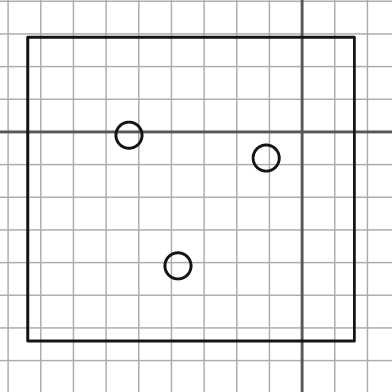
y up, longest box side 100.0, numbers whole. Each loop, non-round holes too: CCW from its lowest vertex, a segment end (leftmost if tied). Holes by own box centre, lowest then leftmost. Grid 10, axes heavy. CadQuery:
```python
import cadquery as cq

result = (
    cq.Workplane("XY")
    .moveTo(-84.0, -64.0)
    .lineTo(16.0, -64.0)
    .lineTo(16.0, 29.0)
    .lineTo(-84.0, 29.0)
    .close()
    .moveTo(-38.0, -41.0)
    .circle(4.0)
    .moveTo(-11.0, -8.0)
    .circle(4.0)
    .moveTo(-53.0, -1.0)
    .circle(4.0)
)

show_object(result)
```